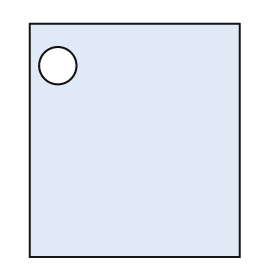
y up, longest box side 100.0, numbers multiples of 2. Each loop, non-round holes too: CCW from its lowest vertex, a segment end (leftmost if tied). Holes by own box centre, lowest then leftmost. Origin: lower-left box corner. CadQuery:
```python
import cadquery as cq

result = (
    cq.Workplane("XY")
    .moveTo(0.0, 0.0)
    .lineTo(90.0, 0.0)
    .lineTo(90.0, 100.0)
    .lineTo(0.0, 100.0)
    .close()
    .moveTo(12.0, 82.0)
    .circle(8.0)
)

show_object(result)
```